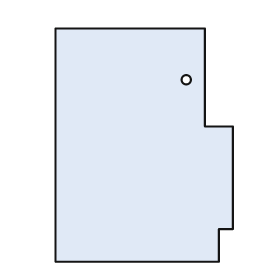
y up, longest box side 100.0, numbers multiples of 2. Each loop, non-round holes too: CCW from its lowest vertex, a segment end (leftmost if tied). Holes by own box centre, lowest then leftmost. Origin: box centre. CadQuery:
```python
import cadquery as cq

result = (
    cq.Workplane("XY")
    .moveTo(-38.0, -50.0)
    .lineTo(32.0, -50.0)
    .lineTo(32.0, -36.0)
    .lineTo(38.0, -36.0)
    .lineTo(38.0, 8.0)
    .lineTo(26.0, 8.0)
    .lineTo(26.0, 50.0)
    .lineTo(-38.0, 50.0)
    .close()
    .moveTo(18.0, 28.0)
    .circle(2.0)
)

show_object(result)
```